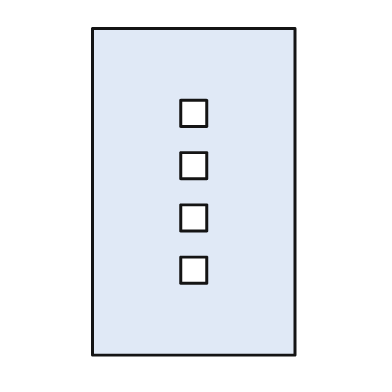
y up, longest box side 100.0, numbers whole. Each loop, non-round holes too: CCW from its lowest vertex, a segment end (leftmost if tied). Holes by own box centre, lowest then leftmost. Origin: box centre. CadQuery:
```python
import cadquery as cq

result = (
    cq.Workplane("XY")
    .moveTo(-31.0, -50.0)
    .lineTo(31.0, -50.0)
    .lineTo(31.0, 50.0)
    .lineTo(-31.0, 50.0)
    .close()
    .moveTo(-4.0, -28.0)
    .lineTo(4.0, -28.0)
    .lineTo(4.0, -20.0)
    .lineTo(-4.0, -20.0)
    .close()
    .moveTo(-4.0, -12.0)
    .lineTo(4.0, -12.0)
    .lineTo(4.0, -4.0)
    .lineTo(-4.0, -4.0)
    .close()
    .moveTo(-4.0, 4.0)
    .lineTo(4.0, 4.0)
    .lineTo(4.0, 12.0)
    .lineTo(-4.0, 12.0)
    .close()
    .moveTo(-4.0, 20.0)
    .lineTo(4.0, 20.0)
    .lineTo(4.0, 28.0)
    .lineTo(-4.0, 28.0)
    .close()
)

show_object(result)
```